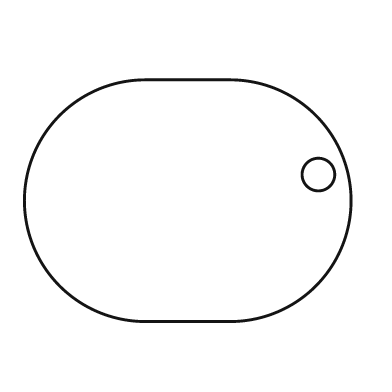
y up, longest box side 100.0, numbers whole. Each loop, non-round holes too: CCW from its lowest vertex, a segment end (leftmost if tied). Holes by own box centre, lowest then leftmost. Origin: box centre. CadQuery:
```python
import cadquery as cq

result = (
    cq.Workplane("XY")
    .moveTo(-13.0, -37.0)
    .lineTo(13.0, -37.0)
    .threePointArc((50.0, 0.0), (13.0, 37.0))
    .lineTo(-13.0, 37.0)
    .threePointArc((-50.0, 0.0), (-13.0, -37.0))
    .close()
    .moveTo(40.0, 8.0)
    .circle(5.0)
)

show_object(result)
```